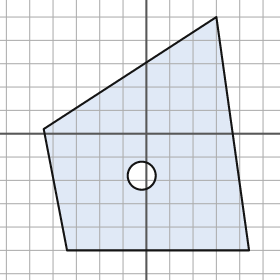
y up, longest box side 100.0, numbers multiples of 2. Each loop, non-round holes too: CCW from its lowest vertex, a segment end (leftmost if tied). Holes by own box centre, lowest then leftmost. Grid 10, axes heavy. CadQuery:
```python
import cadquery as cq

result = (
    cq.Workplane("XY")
    .moveTo(-34.0, -50.0)
    .lineTo(44.0, -50.0)
    .lineTo(30.0, 50.0)
    .lineTo(-44.0, 2.0)
    .close()
    .moveTo(-2.0, -18.0)
    .circle(6.0)
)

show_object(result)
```